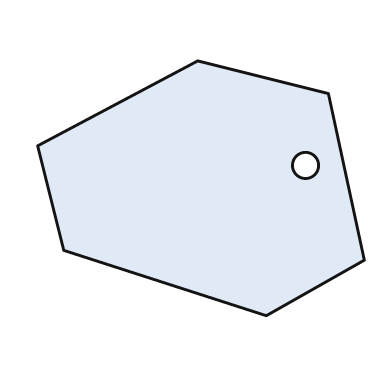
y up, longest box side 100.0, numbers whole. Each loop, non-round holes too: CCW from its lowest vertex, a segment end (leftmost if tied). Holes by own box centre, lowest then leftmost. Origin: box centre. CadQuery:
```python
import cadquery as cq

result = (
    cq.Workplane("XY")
    .moveTo(20.0, -39.0)
    .lineTo(50.0, -22.0)
    .lineTo(39.0, 29.0)
    .lineTo(-1.0, 39.0)
    .lineTo(-50.0, 13.0)
    .lineTo(-42.0, -19.0)
    .close()
    .moveTo(32.0, 7.0)
    .circle(4.0)
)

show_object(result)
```